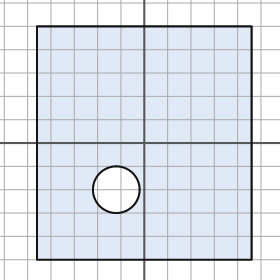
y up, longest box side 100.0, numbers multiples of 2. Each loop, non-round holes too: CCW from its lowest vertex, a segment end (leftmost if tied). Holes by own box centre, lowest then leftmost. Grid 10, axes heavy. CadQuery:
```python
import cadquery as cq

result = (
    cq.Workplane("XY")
    .moveTo(-46.0, -50.0)
    .lineTo(46.0, -50.0)
    .lineTo(46.0, 50.0)
    .lineTo(-46.0, 50.0)
    .close()
    .moveTo(-12.0, -20.0)
    .circle(10.0)
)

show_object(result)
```